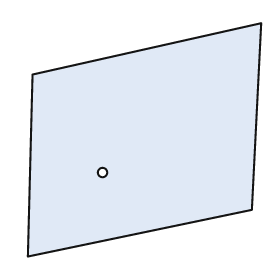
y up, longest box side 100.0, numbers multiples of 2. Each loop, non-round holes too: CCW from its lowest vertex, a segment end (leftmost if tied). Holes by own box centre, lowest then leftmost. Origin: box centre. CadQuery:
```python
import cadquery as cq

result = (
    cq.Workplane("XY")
    .moveTo(-50.0, -50.0)
    .lineTo(46.0, -30.0)
    .lineTo(50.0, 50.0)
    .lineTo(-48.0, 28.0)
    .close()
    .moveTo(-18.0, -14.0)
    .circle(2.0)
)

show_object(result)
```